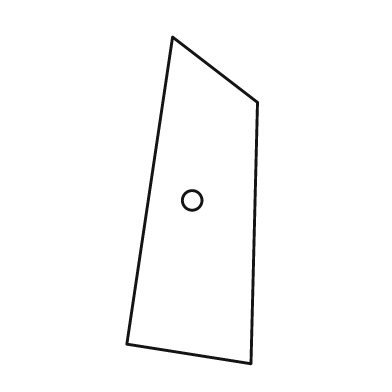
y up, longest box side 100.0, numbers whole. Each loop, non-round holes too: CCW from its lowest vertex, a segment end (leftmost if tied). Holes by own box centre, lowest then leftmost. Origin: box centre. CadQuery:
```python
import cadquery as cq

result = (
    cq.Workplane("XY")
    .moveTo(18.0, -50.0)
    .lineTo(20.0, 30.0)
    .lineTo(-6.0, 50.0)
    .lineTo(-20.0, -44.0)
    .close()
    .moveTo(0.0, 0.0)
    .circle(3.0)
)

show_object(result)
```